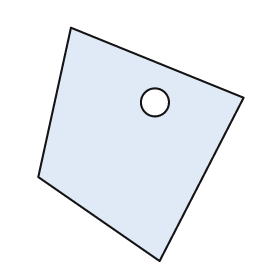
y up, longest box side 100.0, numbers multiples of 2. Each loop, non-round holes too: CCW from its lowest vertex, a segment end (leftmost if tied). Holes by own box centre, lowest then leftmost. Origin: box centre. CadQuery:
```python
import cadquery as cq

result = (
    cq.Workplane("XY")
    .moveTo(8.0, -50.0)
    .lineTo(44.0, 20.0)
    .lineTo(-30.0, 50.0)
    .lineTo(-44.0, -14.0)
    .close()
    .moveTo(6.0, 18.0)
    .circle(6.0)
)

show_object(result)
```